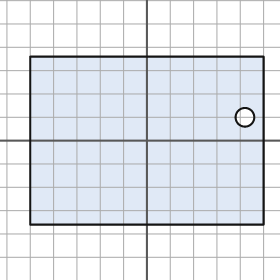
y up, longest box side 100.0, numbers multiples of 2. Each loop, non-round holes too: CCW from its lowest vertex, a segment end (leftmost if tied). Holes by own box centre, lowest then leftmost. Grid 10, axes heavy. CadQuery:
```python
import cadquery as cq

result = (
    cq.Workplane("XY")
    .moveTo(-50.0, -36.0)
    .lineTo(50.0, -36.0)
    .lineTo(50.0, 36.0)
    .lineTo(-50.0, 36.0)
    .close()
    .moveTo(42.0, 10.0)
    .circle(4.0)
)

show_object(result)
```